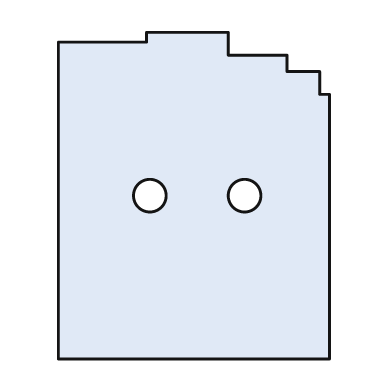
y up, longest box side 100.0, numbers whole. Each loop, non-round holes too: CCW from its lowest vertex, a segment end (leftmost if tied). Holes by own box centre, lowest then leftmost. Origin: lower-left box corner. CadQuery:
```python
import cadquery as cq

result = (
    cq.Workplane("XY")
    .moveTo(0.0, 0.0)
    .lineTo(83.0, 0.0)
    .lineTo(83.0, 81.0)
    .lineTo(80.0, 81.0)
    .lineTo(80.0, 88.0)
    .lineTo(70.0, 88.0)
    .lineTo(70.0, 93.0)
    .lineTo(52.0, 93.0)
    .lineTo(52.0, 100.0)
    .lineTo(27.0, 100.0)
    .lineTo(27.0, 97.0)
    .lineTo(0.0, 97.0)
    .close()
    .moveTo(28.0, 50.0)
    .circle(5.0)
    .moveTo(57.0, 50.0)
    .circle(5.0)
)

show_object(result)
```